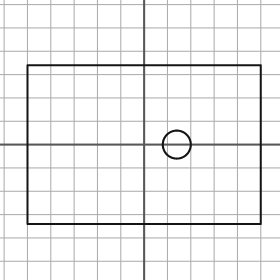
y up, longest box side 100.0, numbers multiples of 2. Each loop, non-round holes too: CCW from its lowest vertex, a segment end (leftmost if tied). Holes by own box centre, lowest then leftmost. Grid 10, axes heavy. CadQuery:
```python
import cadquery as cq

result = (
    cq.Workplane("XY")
    .moveTo(-50.0, -34.0)
    .lineTo(50.0, -34.0)
    .lineTo(50.0, 34.0)
    .lineTo(-50.0, 34.0)
    .close()
    .moveTo(14.0, 0.0)
    .circle(6.0)
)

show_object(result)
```